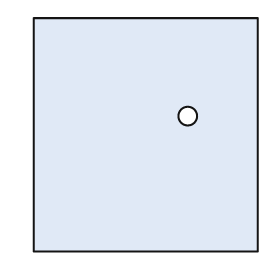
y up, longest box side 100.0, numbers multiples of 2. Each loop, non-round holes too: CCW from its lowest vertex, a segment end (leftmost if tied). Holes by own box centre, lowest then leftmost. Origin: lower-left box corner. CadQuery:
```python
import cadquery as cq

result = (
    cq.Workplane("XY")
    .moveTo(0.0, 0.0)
    .lineTo(96.0, 0.0)
    .lineTo(96.0, 100.0)
    .lineTo(0.0, 100.0)
    .close()
    .moveTo(66.0, 58.0)
    .circle(4.0)
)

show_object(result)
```